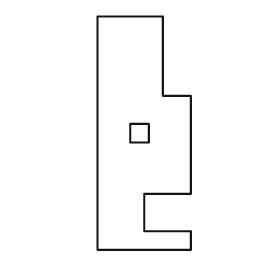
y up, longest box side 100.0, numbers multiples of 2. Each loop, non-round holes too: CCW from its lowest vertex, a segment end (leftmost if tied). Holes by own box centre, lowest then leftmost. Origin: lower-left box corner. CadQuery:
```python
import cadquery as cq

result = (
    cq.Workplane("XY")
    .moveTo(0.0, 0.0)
    .lineTo(40.0, 0.0)
    .lineTo(40.0, 8.0)
    .lineTo(20.0, 8.0)
    .lineTo(20.0, 24.0)
    .lineTo(40.0, 24.0)
    .lineTo(40.0, 66.0)
    .lineTo(28.0, 66.0)
    .lineTo(28.0, 100.0)
    .lineTo(0.0, 100.0)
    .close()
    .moveTo(14.0, 46.0)
    .lineTo(22.0, 46.0)
    .lineTo(22.0, 54.0)
    .lineTo(14.0, 54.0)
    .close()
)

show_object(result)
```